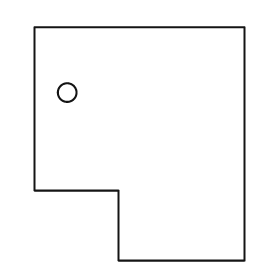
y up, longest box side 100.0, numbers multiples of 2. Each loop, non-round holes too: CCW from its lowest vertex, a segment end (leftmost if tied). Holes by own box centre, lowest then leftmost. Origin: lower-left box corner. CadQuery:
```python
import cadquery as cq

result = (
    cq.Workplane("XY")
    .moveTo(36.0, 0.0)
    .lineTo(90.0, 0.0)
    .lineTo(90.0, 100.0)
    .lineTo(0.0, 100.0)
    .lineTo(0.0, 30.0)
    .lineTo(36.0, 30.0)
    .close()
    .moveTo(14.0, 72.0)
    .circle(4.0)
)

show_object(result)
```